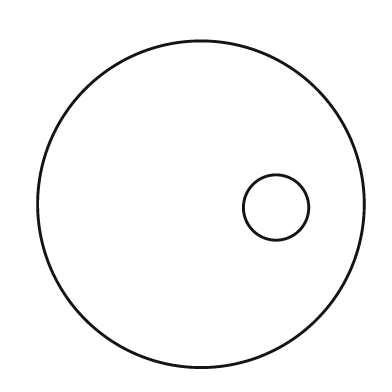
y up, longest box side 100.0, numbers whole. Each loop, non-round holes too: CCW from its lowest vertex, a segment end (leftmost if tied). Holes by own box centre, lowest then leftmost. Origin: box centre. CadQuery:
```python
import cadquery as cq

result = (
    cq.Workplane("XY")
    .moveTo(0.0, 0.0)
    .circle(50.0)
    .moveTo(23.0, -1.0)
    .circle(10.0)
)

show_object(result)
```